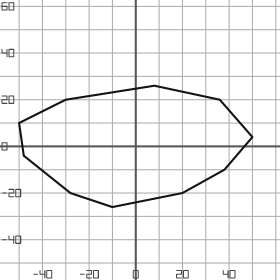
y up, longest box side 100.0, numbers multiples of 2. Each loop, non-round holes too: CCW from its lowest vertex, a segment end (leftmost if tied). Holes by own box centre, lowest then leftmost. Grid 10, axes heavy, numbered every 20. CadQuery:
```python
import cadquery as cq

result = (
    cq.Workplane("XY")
    .moveTo(-10.0, -26.0)
    .lineTo(20.0, -20.0)
    .lineTo(38.0, -10.0)
    .lineTo(50.0, 4.0)
    .lineTo(36.0, 20.0)
    .lineTo(8.0, 26.0)
    .lineTo(-30.0, 20.0)
    .lineTo(-50.0, 10.0)
    .lineTo(-48.0, -4.0)
    .lineTo(-28.0, -20.0)
    .close()
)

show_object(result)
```